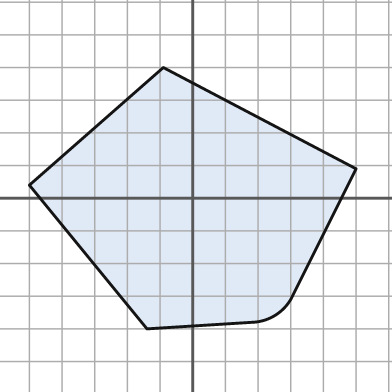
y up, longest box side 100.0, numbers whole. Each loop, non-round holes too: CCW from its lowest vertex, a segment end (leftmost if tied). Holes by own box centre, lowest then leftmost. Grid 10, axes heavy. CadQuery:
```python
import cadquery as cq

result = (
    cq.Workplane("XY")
    .moveTo(-14.0, -40.0)
    .lineTo(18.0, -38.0)
    .threePointArc((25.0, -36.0), (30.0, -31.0))
    .lineTo(50.0, 9.0)
    .lineTo(-9.0, 40.0)
    .lineTo(-50.0, 4.0)
    .close()
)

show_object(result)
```